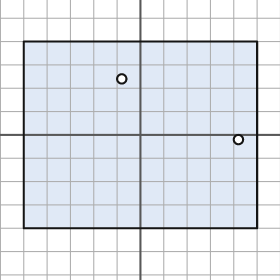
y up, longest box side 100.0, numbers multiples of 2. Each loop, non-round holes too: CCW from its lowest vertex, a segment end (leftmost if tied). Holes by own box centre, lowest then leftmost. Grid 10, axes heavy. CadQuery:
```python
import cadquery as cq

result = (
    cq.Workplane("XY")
    .moveTo(-50.0, -40.0)
    .lineTo(50.0, -40.0)
    .lineTo(50.0, 40.0)
    .lineTo(-50.0, 40.0)
    .close()
    .moveTo(42.0, -2.0)
    .circle(2.0)
    .moveTo(-8.0, 24.0)
    .circle(2.0)
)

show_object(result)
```